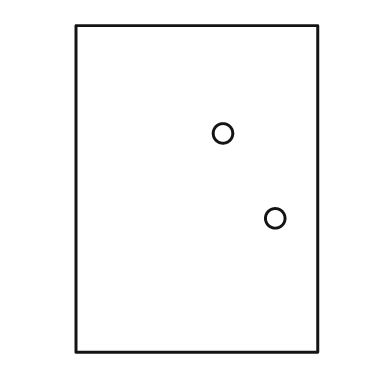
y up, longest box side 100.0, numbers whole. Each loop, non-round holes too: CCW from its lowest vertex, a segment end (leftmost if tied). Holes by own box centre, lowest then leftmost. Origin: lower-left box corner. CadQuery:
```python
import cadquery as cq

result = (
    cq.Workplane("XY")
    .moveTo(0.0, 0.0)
    .lineTo(74.0, 0.0)
    .lineTo(74.0, 100.0)
    .lineTo(0.0, 100.0)
    .close()
    .moveTo(61.0, 41.0)
    .circle(3.0)
    .moveTo(45.0, 67.0)
    .circle(3.0)
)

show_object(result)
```